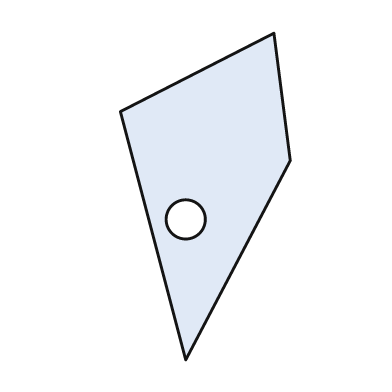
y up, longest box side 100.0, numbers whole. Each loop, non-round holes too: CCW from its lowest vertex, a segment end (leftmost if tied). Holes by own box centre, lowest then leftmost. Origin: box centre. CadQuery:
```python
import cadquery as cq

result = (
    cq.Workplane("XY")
    .moveTo(-6.0, -50.0)
    .lineTo(26.0, 11.0)
    .lineTo(21.0, 50.0)
    .lineTo(-26.0, 26.0)
    .close()
    .moveTo(-6.0, -7.0)
    .circle(6.0)
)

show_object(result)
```